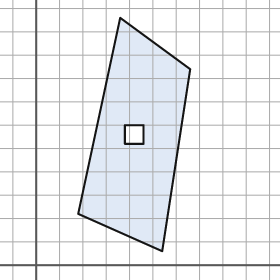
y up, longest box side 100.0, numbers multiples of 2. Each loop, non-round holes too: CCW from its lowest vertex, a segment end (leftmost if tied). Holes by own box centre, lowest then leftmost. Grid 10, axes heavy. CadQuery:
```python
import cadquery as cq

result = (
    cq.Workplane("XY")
    .moveTo(54.0, 6.0)
    .lineTo(66.0, 84.0)
    .lineTo(36.0, 106.0)
    .lineTo(18.0, 22.0)
    .close()
    .moveTo(38.0, 52.0)
    .lineTo(46.0, 52.0)
    .lineTo(46.0, 60.0)
    .lineTo(38.0, 60.0)
    .close()
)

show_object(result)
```